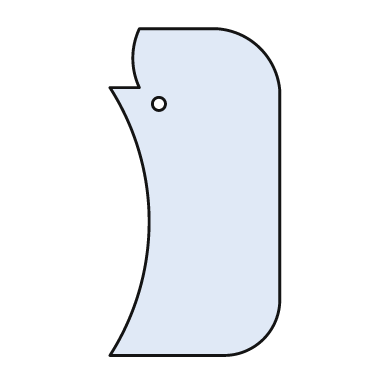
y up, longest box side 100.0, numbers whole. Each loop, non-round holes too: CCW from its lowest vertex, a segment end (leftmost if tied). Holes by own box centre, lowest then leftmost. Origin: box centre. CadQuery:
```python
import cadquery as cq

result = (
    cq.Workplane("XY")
    .moveTo(-26.0, -50.0)
    .lineTo(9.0, -50.0)
    .threePointArc((21.0, -45.0), (26.0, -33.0))
    .lineTo(26.0, 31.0)
    .threePointArc((20.0, 44.0), (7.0, 50.0))
    .lineTo(-17.0, 50.0)
    .threePointArc((-19.0, 41.0), (-17.0, 32.0))
    .lineTo(-26.0, 32.0)
    .threePointArc((-14.0, -9.0), (-26.0, -50.0))
    .close()
    .moveTo(-11.0, 27.0)
    .circle(2.0)
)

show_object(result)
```